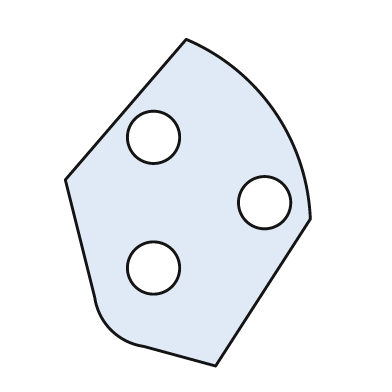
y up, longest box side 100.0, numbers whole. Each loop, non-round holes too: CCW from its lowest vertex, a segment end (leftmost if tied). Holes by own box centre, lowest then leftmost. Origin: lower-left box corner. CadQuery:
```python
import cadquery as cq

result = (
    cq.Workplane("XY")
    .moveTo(46.0, 0.0)
    .lineTo(75.0, 45.0)
    .threePointArc((64.0, 78.0), (37.0, 100.0))
    .lineTo(0.0, 57.0)
    .lineTo(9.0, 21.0)
    .threePointArc((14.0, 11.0), (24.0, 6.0))
    .close()
    .moveTo(27.0, 30.0)
    .circle(8.0)
    .moveTo(61.0, 50.0)
    .circle(8.0)
    .moveTo(27.0, 70.0)
    .circle(8.0)
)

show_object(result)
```